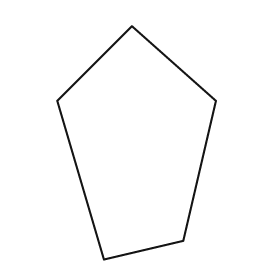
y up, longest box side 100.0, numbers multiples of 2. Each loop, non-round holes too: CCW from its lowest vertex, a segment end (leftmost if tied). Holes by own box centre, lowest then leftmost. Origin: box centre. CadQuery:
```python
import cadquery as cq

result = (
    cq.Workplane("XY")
    .moveTo(-14.0, -50.0)
    .lineTo(20.0, -42.0)
    .lineTo(34.0, 18.0)
    .lineTo(-2.0, 50.0)
    .lineTo(-34.0, 18.0)
    .close()
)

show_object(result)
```